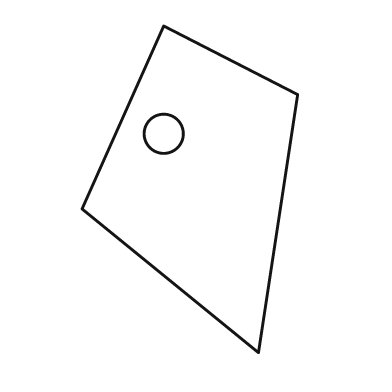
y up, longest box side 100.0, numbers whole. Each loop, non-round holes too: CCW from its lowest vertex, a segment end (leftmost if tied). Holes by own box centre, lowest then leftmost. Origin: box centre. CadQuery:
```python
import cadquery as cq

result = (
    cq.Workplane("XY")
    .moveTo(21.0, -50.0)
    .lineTo(33.0, 29.0)
    .lineTo(-8.0, 50.0)
    .lineTo(-33.0, -6.0)
    .close()
    .moveTo(-8.0, 17.0)
    .circle(6.0)
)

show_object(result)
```